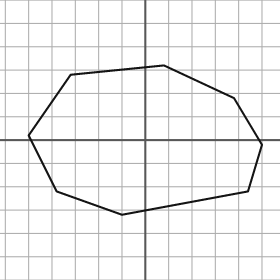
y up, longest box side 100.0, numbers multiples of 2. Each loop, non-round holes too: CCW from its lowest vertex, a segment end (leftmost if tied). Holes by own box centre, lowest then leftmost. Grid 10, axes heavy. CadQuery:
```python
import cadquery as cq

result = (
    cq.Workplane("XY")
    .moveTo(-10.0, -32.0)
    .lineTo(44.0, -22.0)
    .lineTo(50.0, -2.0)
    .lineTo(38.0, 18.0)
    .lineTo(8.0, 32.0)
    .lineTo(-32.0, 28.0)
    .lineTo(-50.0, 2.0)
    .lineTo(-38.0, -22.0)
    .close()
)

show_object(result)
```